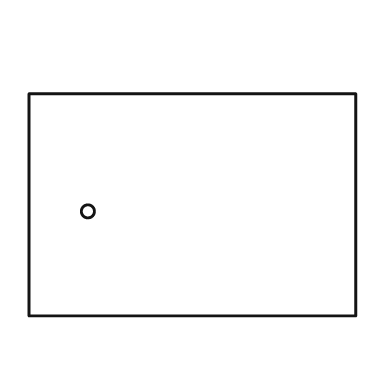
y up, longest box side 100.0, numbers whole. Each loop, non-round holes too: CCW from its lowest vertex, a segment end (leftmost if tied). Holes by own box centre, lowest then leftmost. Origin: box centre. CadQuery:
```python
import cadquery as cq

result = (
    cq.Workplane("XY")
    .moveTo(-50.0, -34.0)
    .lineTo(50.0, -34.0)
    .lineTo(50.0, 34.0)
    .lineTo(-50.0, 34.0)
    .close()
    .moveTo(-32.0, -2.0)
    .circle(2.0)
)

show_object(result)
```